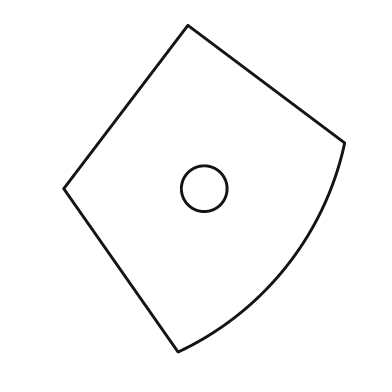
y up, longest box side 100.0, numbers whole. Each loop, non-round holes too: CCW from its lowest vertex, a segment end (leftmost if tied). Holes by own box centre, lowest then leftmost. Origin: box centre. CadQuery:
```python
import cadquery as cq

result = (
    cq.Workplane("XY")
    .moveTo(-8.0, -50.0)
    .threePointArc((25.0, -24.0), (43.0, 14.0))
    .lineTo(-5.0, 50.0)
    .lineTo(-43.0, 0.0)
    .close()
    .moveTo(0.0, 0.0)
    .circle(7.0)
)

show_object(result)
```